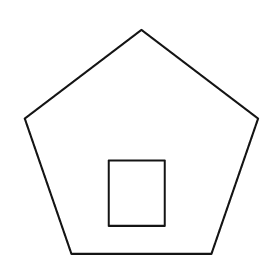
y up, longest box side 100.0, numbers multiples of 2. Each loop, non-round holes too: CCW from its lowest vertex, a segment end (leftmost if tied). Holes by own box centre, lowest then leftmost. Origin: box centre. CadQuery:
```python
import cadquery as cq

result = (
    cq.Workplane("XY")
    .moveTo(-30.0, -48.0)
    .lineTo(30.0, -48.0)
    .lineTo(50.0, 10.0)
    .lineTo(0.0, 48.0)
    .lineTo(-50.0, 10.0)
    .close()
    .moveTo(-14.0, -36.0)
    .lineTo(10.0, -36.0)
    .lineTo(10.0, -8.0)
    .lineTo(-14.0, -8.0)
    .close()
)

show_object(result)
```